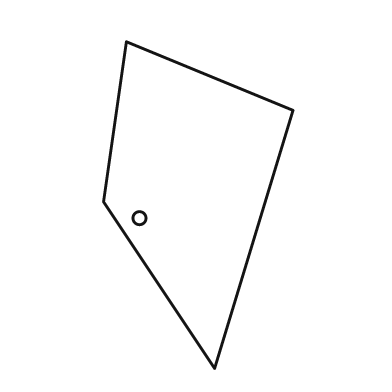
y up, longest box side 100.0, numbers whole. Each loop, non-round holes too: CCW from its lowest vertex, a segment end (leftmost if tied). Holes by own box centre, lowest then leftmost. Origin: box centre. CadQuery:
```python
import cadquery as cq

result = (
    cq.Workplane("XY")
    .moveTo(5.0, -50.0)
    .lineTo(29.0, 29.0)
    .lineTo(-22.0, 50.0)
    .lineTo(-29.0, 1.0)
    .close()
    .moveTo(-18.0, -4.0)
    .circle(2.0)
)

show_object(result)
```